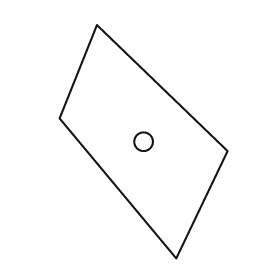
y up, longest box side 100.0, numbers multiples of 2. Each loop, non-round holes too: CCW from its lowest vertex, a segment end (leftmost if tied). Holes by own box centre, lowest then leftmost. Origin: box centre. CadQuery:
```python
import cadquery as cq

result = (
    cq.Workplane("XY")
    .moveTo(14.0, -50.0)
    .lineTo(36.0, -4.0)
    .lineTo(-20.0, 50.0)
    .lineTo(-36.0, 10.0)
    .close()
    .moveTo(0.0, 0.0)
    .circle(4.0)
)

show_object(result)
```